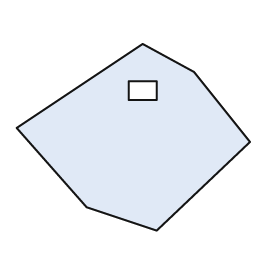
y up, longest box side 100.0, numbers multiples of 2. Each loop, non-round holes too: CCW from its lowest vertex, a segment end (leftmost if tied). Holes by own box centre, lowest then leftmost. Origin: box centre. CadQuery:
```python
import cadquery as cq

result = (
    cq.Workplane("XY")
    .moveTo(10.0, -40.0)
    .lineTo(50.0, -2.0)
    .lineTo(26.0, 28.0)
    .lineTo(4.0, 40.0)
    .lineTo(-50.0, 4.0)
    .lineTo(-20.0, -30.0)
    .close()
    .moveTo(-2.0, 16.0)
    .lineTo(10.0, 16.0)
    .lineTo(10.0, 24.0)
    .lineTo(-2.0, 24.0)
    .close()
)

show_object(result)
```